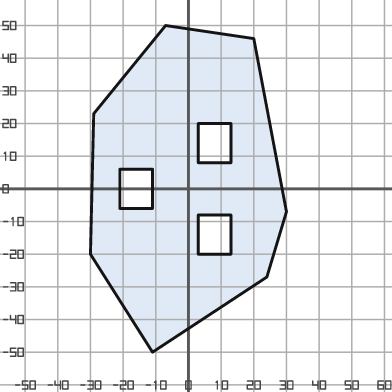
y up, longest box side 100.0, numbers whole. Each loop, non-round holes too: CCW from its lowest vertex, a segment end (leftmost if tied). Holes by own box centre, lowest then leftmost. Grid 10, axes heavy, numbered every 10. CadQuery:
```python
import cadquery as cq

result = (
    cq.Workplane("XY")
    .moveTo(-11.0, -50.0)
    .lineTo(24.0, -27.0)
    .lineTo(30.0, -7.0)
    .lineTo(20.0, 46.0)
    .lineTo(-7.0, 50.0)
    .lineTo(-29.0, 23.0)
    .lineTo(-30.0, -20.0)
    .close()
    .moveTo(3.0, -20.0)
    .lineTo(13.0, -20.0)
    .lineTo(13.0, -8.0)
    .lineTo(3.0, -8.0)
    .close()
    .moveTo(-21.0, -6.0)
    .lineTo(-11.0, -6.0)
    .lineTo(-11.0, 6.0)
    .lineTo(-21.0, 6.0)
    .close()
    .moveTo(3.0, 8.0)
    .lineTo(13.0, 8.0)
    .lineTo(13.0, 20.0)
    .lineTo(3.0, 20.0)
    .close()
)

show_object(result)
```